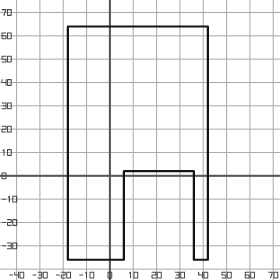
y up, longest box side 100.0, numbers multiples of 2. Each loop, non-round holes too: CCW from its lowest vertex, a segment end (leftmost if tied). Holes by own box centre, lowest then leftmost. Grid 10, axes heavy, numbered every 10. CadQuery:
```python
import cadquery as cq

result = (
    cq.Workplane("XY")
    .moveTo(-18.0, -36.0)
    .lineTo(6.0, -36.0)
    .lineTo(6.0, 2.0)
    .lineTo(36.0, 2.0)
    .lineTo(36.0, -36.0)
    .lineTo(42.0, -36.0)
    .lineTo(42.0, 64.0)
    .lineTo(-18.0, 64.0)
    .close()
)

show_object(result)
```